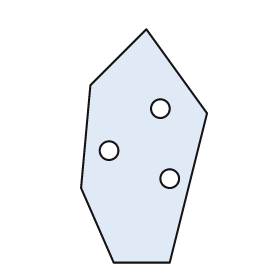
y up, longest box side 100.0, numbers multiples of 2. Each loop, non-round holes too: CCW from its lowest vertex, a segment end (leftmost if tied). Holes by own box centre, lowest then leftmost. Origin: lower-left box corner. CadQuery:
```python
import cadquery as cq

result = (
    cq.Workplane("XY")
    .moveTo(14.0, 0.0)
    .lineTo(38.0, 0.0)
    .lineTo(54.0, 64.0)
    .lineTo(28.0, 100.0)
    .lineTo(4.0, 76.0)
    .lineTo(0.0, 32.0)
    .close()
    .moveTo(38.0, 36.0)
    .circle(4.0)
    .moveTo(12.0, 48.0)
    .circle(4.0)
    .moveTo(34.0, 66.0)
    .circle(4.0)
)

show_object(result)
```